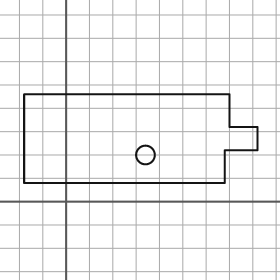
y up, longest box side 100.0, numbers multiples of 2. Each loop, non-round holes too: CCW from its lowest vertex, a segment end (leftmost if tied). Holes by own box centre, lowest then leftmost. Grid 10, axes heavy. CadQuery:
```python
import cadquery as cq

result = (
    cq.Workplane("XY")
    .moveTo(-18.0, 8.0)
    .lineTo(68.0, 8.0)
    .lineTo(68.0, 22.0)
    .lineTo(82.0, 22.0)
    .lineTo(82.0, 32.0)
    .lineTo(70.0, 32.0)
    .lineTo(70.0, 46.0)
    .lineTo(-18.0, 46.0)
    .close()
    .moveTo(34.0, 20.0)
    .circle(4.0)
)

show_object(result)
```